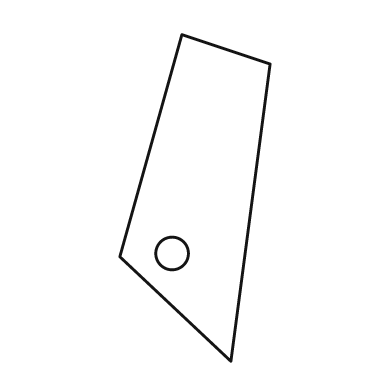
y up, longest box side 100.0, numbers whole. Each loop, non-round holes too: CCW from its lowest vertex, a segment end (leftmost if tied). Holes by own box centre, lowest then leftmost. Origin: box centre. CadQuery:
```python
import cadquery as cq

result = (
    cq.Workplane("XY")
    .moveTo(11.0, -50.0)
    .lineTo(23.0, 41.0)
    .lineTo(-4.0, 50.0)
    .lineTo(-23.0, -18.0)
    .close()
    .moveTo(-7.0, -17.0)
    .circle(5.0)
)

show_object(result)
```